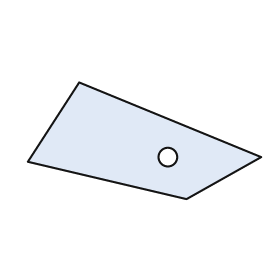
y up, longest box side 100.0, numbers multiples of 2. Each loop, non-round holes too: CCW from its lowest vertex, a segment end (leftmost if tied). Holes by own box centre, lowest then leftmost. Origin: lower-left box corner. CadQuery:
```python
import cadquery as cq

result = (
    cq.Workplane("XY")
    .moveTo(68.0, 0.0)
    .lineTo(100.0, 18.0)
    .lineTo(22.0, 50.0)
    .lineTo(0.0, 16.0)
    .close()
    .moveTo(60.0, 18.0)
    .circle(4.0)
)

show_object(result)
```